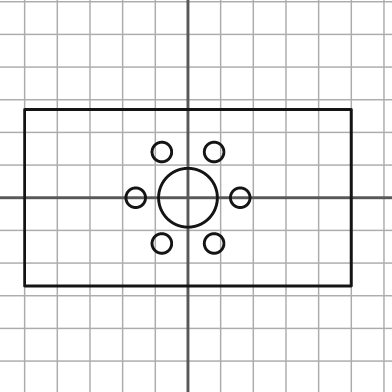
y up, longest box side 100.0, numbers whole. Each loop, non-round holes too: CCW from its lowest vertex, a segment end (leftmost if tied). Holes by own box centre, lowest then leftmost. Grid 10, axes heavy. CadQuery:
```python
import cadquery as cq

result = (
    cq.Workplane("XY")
    .moveTo(-50.0, -27.0)
    .lineTo(50.0, -27.0)
    .lineTo(50.0, 27.0)
    .lineTo(-50.0, 27.0)
    .close()
    .moveTo(-8.0, -14.0)
    .circle(3.0)
    .moveTo(8.0, -14.0)
    .circle(3.0)
    .moveTo(-16.0, 0.0)
    .circle(3.0)
    .moveTo(0.0, 0.0)
    .circle(9.0)
    .moveTo(16.0, 0.0)
    .circle(3.0)
    .moveTo(-8.0, 14.0)
    .circle(3.0)
    .moveTo(8.0, 14.0)
    .circle(3.0)
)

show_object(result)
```